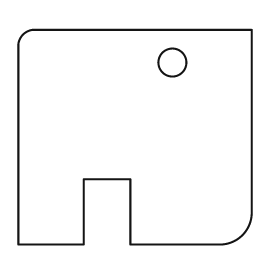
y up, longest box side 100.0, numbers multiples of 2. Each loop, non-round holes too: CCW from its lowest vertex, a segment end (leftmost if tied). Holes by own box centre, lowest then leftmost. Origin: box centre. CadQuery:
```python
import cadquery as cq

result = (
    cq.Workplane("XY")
    .moveTo(-50.0, -46.0)
    .lineTo(-22.0, -46.0)
    .lineTo(-22.0, -18.0)
    .lineTo(-2.0, -18.0)
    .lineTo(-2.0, -46.0)
    .lineTo(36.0, -46.0)
    .threePointArc((46.0, -42.0), (50.0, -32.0))
    .lineTo(50.0, 46.0)
    .lineTo(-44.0, 46.0)
    .threePointArc((-48.0, 44.0), (-50.0, 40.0))
    .close()
    .moveTo(16.0, 32.0)
    .circle(6.0)
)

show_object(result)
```